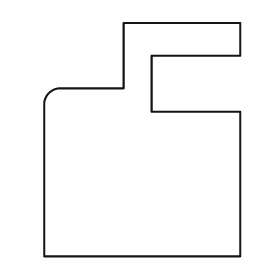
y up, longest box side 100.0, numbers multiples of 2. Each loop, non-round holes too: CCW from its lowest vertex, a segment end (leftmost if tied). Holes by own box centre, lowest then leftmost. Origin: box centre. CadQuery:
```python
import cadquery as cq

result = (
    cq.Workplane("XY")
    .moveTo(-42.0, -50.0)
    .lineTo(42.0, -50.0)
    .lineTo(42.0, 12.0)
    .lineTo(4.0, 12.0)
    .lineTo(4.0, 36.0)
    .lineTo(42.0, 36.0)
    .lineTo(42.0, 50.0)
    .lineTo(-8.0, 50.0)
    .lineTo(-8.0, 22.0)
    .lineTo(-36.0, 22.0)
    .threePointArc((-40.0, 20.0), (-42.0, 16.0))
    .close()
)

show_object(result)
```